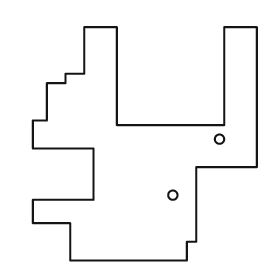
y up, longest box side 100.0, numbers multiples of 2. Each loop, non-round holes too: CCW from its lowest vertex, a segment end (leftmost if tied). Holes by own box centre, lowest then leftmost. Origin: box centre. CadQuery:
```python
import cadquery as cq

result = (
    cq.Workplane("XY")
    .moveTo(-32.0, -50.0)
    .lineTo(18.0, -50.0)
    .lineTo(18.0, -42.0)
    .lineTo(22.0, -42.0)
    .lineTo(22.0, -10.0)
    .lineTo(48.0, -10.0)
    .lineTo(48.0, 50.0)
    .lineTo(34.0, 50.0)
    .lineTo(34.0, 8.0)
    .lineTo(-12.0, 8.0)
    .lineTo(-12.0, 50.0)
    .lineTo(-26.0, 50.0)
    .lineTo(-26.0, 30.0)
    .lineTo(-34.0, 30.0)
    .lineTo(-34.0, 26.0)
    .lineTo(-42.0, 26.0)
    .lineTo(-42.0, 10.0)
    .lineTo(-48.0, 10.0)
    .lineTo(-48.0, -2.0)
    .lineTo(-22.0, -2.0)
    .lineTo(-22.0, -24.0)
    .lineTo(-48.0, -24.0)
    .lineTo(-48.0, -34.0)
    .lineTo(-32.0, -34.0)
    .close()
    .moveTo(12.0, -22.0)
    .circle(2.0)
    .moveTo(32.0, 2.0)
    .circle(2.0)
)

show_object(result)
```